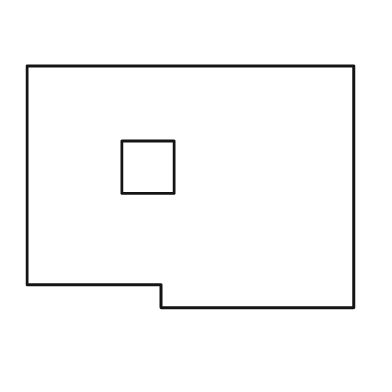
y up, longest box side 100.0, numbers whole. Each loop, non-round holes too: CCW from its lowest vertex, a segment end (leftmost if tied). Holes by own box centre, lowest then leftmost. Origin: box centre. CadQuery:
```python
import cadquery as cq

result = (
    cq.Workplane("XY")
    .moveTo(-9.0, -37.0)
    .lineTo(50.0, -37.0)
    .lineTo(50.0, 37.0)
    .lineTo(-50.0, 37.0)
    .lineTo(-50.0, -30.0)
    .lineTo(-9.0, -30.0)
    .close()
    .moveTo(-21.0, -2.0)
    .lineTo(-5.0, -2.0)
    .lineTo(-5.0, 14.0)
    .lineTo(-21.0, 14.0)
    .close()
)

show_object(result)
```